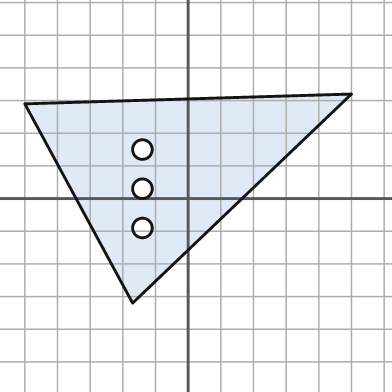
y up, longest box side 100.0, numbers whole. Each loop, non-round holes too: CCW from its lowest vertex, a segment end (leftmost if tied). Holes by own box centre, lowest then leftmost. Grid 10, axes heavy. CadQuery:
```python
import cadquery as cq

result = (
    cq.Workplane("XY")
    .moveTo(-17.0, -32.0)
    .lineTo(50.0, 32.0)
    .lineTo(-50.0, 29.0)
    .close()
    .moveTo(-14.0, -9.0)
    .circle(3.0)
    .moveTo(-14.0, 3.0)
    .circle(3.0)
    .moveTo(-14.0, 15.0)
    .circle(3.0)
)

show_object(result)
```